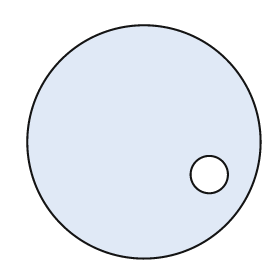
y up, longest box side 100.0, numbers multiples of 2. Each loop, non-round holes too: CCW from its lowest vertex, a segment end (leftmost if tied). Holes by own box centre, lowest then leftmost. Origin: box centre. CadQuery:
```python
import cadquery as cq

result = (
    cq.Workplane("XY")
    .moveTo(0.0, 0.0)
    .circle(50.0)
    .moveTo(28.0, -14.0)
    .circle(8.0)
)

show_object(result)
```